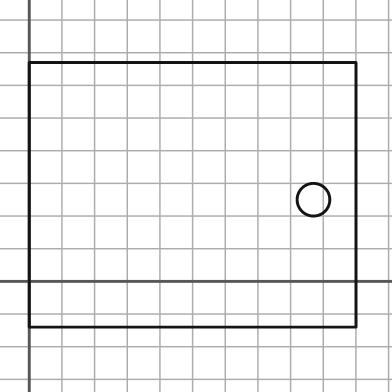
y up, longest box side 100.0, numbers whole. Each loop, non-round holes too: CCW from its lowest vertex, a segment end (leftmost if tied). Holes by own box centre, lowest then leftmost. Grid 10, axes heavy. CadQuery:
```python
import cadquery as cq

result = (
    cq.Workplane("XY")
    .moveTo(0.0, -14.0)
    .lineTo(100.0, -14.0)
    .lineTo(100.0, 67.0)
    .lineTo(0.0, 67.0)
    .close()
    .moveTo(87.0, 25.0)
    .circle(5.0)
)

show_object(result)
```